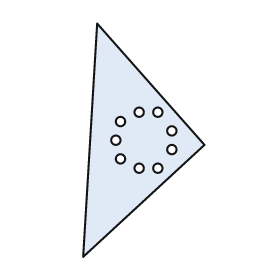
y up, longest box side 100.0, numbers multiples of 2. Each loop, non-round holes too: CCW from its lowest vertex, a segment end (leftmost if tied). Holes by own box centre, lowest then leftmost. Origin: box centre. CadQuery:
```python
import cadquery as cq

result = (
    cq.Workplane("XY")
    .moveTo(-26.0, -50.0)
    .lineTo(26.0, -2.0)
    .lineTo(-20.0, 50.0)
    .close()
    .moveTo(-2.0, -12.0)
    .circle(2.0)
    .moveTo(6.0, -12.0)
    .circle(2.0)
    .moveTo(-10.0, -8.0)
    .circle(2.0)
    .moveTo(12.0, -4.0)
    .circle(2.0)
    .moveTo(-12.0, 0.0)
    .circle(2.0)
    .moveTo(12.0, 4.0)
    .circle(2.0)
    .moveTo(-10.0, 8.0)
    .circle(2.0)
    .moveTo(-2.0, 12.0)
    .circle(2.0)
    .moveTo(6.0, 12.0)
    .circle(2.0)
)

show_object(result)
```